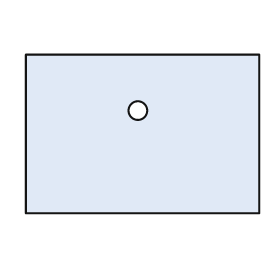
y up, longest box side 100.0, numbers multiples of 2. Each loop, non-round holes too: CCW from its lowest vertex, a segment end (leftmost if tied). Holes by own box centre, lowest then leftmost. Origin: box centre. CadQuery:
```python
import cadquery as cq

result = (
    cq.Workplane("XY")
    .moveTo(-50.0, -34.0)
    .lineTo(50.0, -34.0)
    .lineTo(50.0, 34.0)
    .lineTo(-50.0, 34.0)
    .close()
    .moveTo(-2.0, 10.0)
    .circle(4.0)
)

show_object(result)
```